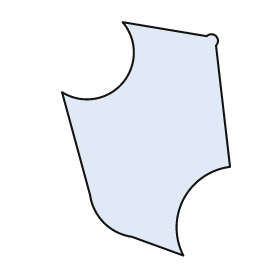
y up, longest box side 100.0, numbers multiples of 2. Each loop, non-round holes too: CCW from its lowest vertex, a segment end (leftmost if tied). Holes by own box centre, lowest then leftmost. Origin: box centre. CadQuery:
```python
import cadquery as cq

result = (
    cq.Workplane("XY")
    .moveTo(16.0, -50.0)
    .threePointArc((16.0, -26.0), (36.0, -12.0))
    .lineTo(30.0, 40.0)
    .threePointArc((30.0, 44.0), (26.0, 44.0))
    .lineTo(-10.0, 50.0)
    .threePointArc((-10.0, 24.0), (-36.0, 20.0))
    .lineTo(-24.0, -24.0)
    .threePointArc((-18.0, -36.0), (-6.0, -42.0))
    .close()
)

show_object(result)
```